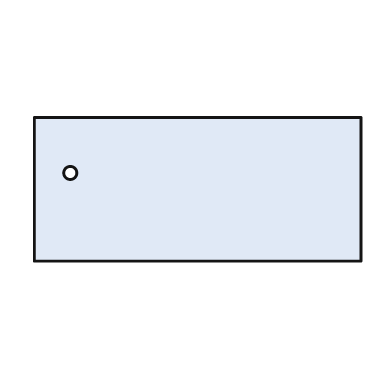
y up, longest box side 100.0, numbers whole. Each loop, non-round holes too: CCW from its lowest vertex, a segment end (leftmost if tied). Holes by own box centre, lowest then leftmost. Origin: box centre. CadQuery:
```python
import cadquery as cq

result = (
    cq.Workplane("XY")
    .moveTo(-50.0, -22.0)
    .lineTo(50.0, -22.0)
    .lineTo(50.0, 22.0)
    .lineTo(-50.0, 22.0)
    .close()
    .moveTo(-39.0, 5.0)
    .circle(2.0)
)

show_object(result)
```